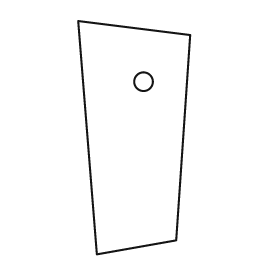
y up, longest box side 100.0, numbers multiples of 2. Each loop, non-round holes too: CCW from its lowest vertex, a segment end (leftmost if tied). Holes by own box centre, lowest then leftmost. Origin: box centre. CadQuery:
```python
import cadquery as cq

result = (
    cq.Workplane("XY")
    .moveTo(-16.0, -50.0)
    .lineTo(18.0, -44.0)
    .lineTo(24.0, 44.0)
    .lineTo(-24.0, 50.0)
    .close()
    .moveTo(4.0, 24.0)
    .circle(4.0)
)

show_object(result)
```